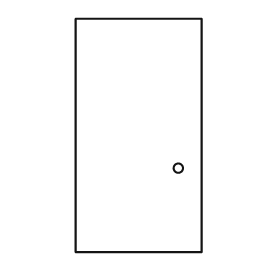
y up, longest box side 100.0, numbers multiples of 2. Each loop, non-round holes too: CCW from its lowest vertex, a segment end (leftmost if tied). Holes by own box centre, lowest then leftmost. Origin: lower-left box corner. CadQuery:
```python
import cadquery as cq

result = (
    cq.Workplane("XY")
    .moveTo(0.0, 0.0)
    .lineTo(54.0, 0.0)
    .lineTo(54.0, 100.0)
    .lineTo(0.0, 100.0)
    .close()
    .moveTo(44.0, 36.0)
    .circle(2.0)
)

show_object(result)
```